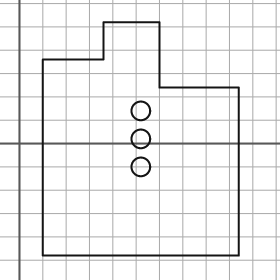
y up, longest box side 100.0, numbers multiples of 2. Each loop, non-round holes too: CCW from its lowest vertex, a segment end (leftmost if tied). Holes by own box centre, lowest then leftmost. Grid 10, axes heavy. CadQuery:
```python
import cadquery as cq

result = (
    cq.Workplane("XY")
    .moveTo(10.0, -48.0)
    .lineTo(94.0, -48.0)
    .lineTo(94.0, 24.0)
    .lineTo(60.0, 24.0)
    .lineTo(60.0, 52.0)
    .lineTo(36.0, 52.0)
    .lineTo(36.0, 36.0)
    .lineTo(10.0, 36.0)
    .close()
    .moveTo(52.0, -10.0)
    .circle(4.0)
    .moveTo(52.0, 2.0)
    .circle(4.0)
    .moveTo(52.0, 14.0)
    .circle(4.0)
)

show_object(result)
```